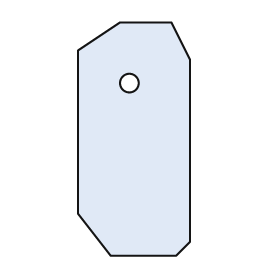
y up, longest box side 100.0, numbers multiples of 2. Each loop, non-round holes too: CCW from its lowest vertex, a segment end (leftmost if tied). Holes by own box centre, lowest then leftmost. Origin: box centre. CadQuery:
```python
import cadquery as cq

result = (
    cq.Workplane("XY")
    .moveTo(-10.0, -50.0)
    .lineTo(18.0, -50.0)
    .lineTo(24.0, -44.0)
    .lineTo(24.0, 34.0)
    .lineTo(16.0, 50.0)
    .lineTo(-6.0, 50.0)
    .lineTo(-24.0, 38.0)
    .lineTo(-24.0, -32.0)
    .close()
    .moveTo(-2.0, 24.0)
    .circle(4.0)
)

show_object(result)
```